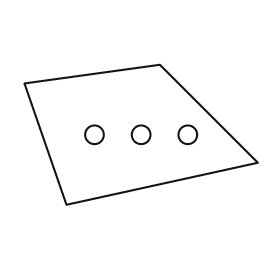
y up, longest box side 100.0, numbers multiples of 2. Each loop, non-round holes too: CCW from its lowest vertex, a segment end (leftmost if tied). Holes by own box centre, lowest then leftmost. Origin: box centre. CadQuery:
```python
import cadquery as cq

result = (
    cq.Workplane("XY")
    .moveTo(-32.0, -30.0)
    .lineTo(50.0, -12.0)
    .lineTo(8.0, 30.0)
    .lineTo(-50.0, 22.0)
    .close()
    .moveTo(-20.0, 0.0)
    .circle(4.0)
    .moveTo(0.0, 0.0)
    .circle(4.0)
    .moveTo(20.0, 0.0)
    .circle(4.0)
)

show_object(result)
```